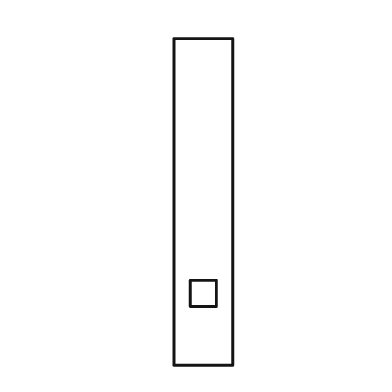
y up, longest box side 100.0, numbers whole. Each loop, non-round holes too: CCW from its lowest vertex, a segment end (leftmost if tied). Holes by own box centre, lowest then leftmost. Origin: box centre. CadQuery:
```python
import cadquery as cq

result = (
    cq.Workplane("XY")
    .moveTo(-9.0, -50.0)
    .lineTo(9.0, -50.0)
    .lineTo(9.0, 50.0)
    .lineTo(-9.0, 50.0)
    .close()
    .moveTo(-4.0, -32.0)
    .lineTo(4.0, -32.0)
    .lineTo(4.0, -24.0)
    .lineTo(-4.0, -24.0)
    .close()
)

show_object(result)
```